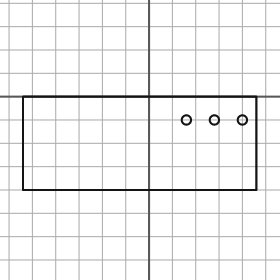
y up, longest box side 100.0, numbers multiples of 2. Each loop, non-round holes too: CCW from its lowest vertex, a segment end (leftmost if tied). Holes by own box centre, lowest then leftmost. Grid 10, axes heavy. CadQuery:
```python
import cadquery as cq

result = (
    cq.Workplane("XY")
    .moveTo(-54.0, -40.0)
    .lineTo(46.0, -40.0)
    .lineTo(46.0, 0.0)
    .lineTo(-54.0, 0.0)
    .close()
    .moveTo(16.0, -10.0)
    .circle(2.0)
    .moveTo(28.0, -10.0)
    .circle(2.0)
    .moveTo(40.0, -10.0)
    .circle(2.0)
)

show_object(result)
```